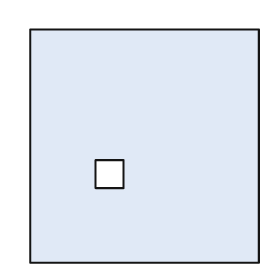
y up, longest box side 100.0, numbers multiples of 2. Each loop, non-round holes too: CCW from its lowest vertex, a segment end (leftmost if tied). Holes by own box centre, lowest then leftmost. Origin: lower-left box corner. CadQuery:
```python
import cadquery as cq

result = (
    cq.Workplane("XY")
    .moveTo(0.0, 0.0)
    .lineTo(98.0, 0.0)
    .lineTo(98.0, 100.0)
    .lineTo(0.0, 100.0)
    .close()
    .moveTo(28.0, 32.0)
    .lineTo(40.0, 32.0)
    .lineTo(40.0, 44.0)
    .lineTo(28.0, 44.0)
    .close()
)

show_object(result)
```